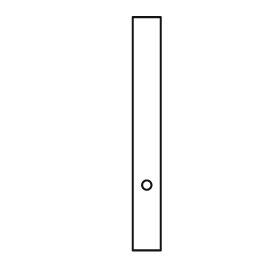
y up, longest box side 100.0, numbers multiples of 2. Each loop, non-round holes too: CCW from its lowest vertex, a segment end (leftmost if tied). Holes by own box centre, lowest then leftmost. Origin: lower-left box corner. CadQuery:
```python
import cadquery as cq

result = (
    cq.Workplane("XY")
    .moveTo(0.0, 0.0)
    .lineTo(12.0, 0.0)
    .lineTo(12.0, 100.0)
    .lineTo(0.0, 100.0)
    .close()
    .moveTo(6.0, 28.0)
    .circle(2.0)
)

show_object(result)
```